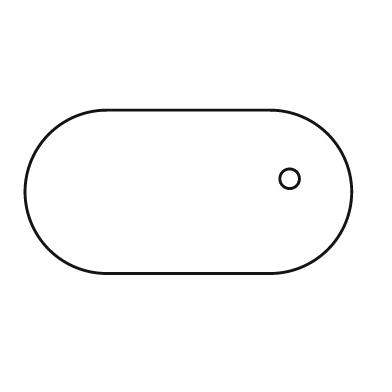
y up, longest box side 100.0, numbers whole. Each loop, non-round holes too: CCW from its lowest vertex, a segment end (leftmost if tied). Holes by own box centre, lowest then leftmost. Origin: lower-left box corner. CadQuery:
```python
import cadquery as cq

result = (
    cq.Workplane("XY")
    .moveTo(25.0, 0.0)
    .lineTo(75.0, 0.0)
    .threePointArc((100.0, 25.0), (75.0, 50.0))
    .lineTo(25.0, 50.0)
    .threePointArc((0.0, 25.0), (25.0, 0.0))
    .close()
    .moveTo(81.0, 29.0)
    .circle(3.0)
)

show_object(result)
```